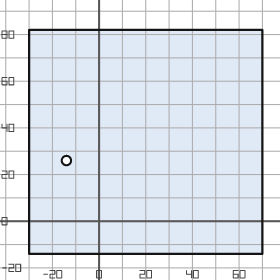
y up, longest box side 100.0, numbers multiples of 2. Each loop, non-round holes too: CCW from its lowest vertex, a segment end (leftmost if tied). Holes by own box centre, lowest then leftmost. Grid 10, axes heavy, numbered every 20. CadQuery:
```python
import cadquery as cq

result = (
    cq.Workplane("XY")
    .moveTo(-30.0, -14.0)
    .lineTo(70.0, -14.0)
    .lineTo(70.0, 82.0)
    .lineTo(-30.0, 82.0)
    .close()
    .moveTo(-14.0, 26.0)
    .circle(2.0)
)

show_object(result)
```